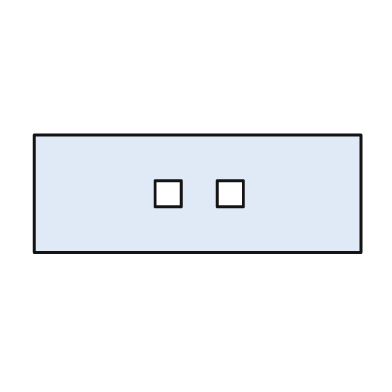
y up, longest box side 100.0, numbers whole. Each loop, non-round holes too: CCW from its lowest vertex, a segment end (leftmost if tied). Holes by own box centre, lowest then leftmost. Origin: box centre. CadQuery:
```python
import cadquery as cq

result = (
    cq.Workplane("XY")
    .moveTo(-50.0, -18.0)
    .lineTo(50.0, -18.0)
    .lineTo(50.0, 18.0)
    .lineTo(-50.0, 18.0)
    .close()
    .moveTo(-13.0, -4.0)
    .lineTo(-5.0, -4.0)
    .lineTo(-5.0, 4.0)
    .lineTo(-13.0, 4.0)
    .close()
    .moveTo(6.0, -4.0)
    .lineTo(14.0, -4.0)
    .lineTo(14.0, 4.0)
    .lineTo(6.0, 4.0)
    .close()
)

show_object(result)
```